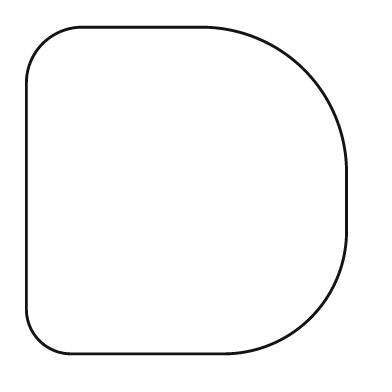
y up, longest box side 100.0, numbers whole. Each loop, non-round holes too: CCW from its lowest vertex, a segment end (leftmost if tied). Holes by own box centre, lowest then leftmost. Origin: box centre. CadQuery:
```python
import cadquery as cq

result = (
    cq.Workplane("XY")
    .moveTo(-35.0, -50.0)
    .lineTo(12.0, -50.0)
    .threePointArc((38.0, -39.0), (49.0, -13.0))
    .lineTo(49.0, 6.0)
    .threePointArc((36.0, 37.0), (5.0, 50.0))
    .lineTo(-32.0, 50.0)
    .threePointArc((-44.0, 45.0), (-49.0, 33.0))
    .lineTo(-49.0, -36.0)
    .threePointArc((-45.0, -46.0), (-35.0, -50.0))
    .close()
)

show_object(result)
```